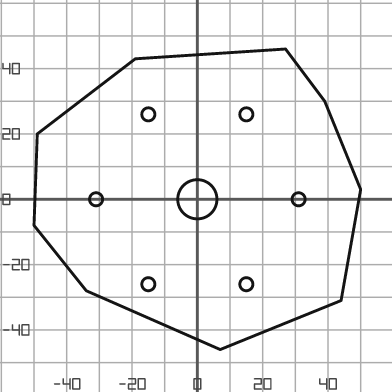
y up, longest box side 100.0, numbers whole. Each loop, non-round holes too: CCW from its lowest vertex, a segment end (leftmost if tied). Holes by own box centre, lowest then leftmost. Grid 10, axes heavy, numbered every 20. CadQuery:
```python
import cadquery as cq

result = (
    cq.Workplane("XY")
    .moveTo(7.0, -46.0)
    .lineTo(44.0, -31.0)
    .lineTo(50.0, 3.0)
    .lineTo(39.0, 30.0)
    .lineTo(27.0, 46.0)
    .lineTo(-19.0, 43.0)
    .lineTo(-49.0, 20.0)
    .lineTo(-50.0, -8.0)
    .lineTo(-34.0, -28.0)
    .close()
    .moveTo(-15.0, -26.0)
    .circle(2.0)
    .moveTo(15.0, -26.0)
    .circle(2.0)
    .moveTo(-31.0, 0.0)
    .circle(2.0)
    .moveTo(0.0, 0.0)
    .circle(6.0)
    .moveTo(31.0, 0.0)
    .circle(2.0)
    .moveTo(-15.0, 26.0)
    .circle(2.0)
    .moveTo(15.0, 26.0)
    .circle(2.0)
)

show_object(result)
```